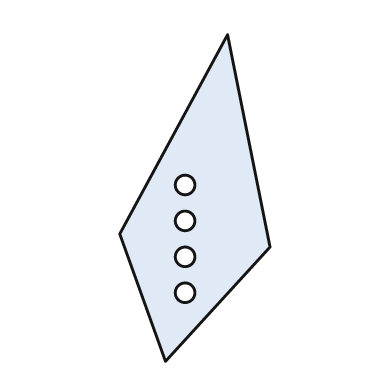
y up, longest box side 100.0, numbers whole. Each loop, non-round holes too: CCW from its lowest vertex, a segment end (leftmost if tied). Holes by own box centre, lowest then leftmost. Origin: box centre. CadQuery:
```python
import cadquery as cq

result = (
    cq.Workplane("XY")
    .moveTo(-9.0, -50.0)
    .lineTo(23.0, -15.0)
    .lineTo(10.0, 50.0)
    .lineTo(-23.0, -11.0)
    .close()
    .moveTo(-3.0, -29.0)
    .circle(3.0)
    .moveTo(-3.0, -18.0)
    .circle(3.0)
    .moveTo(-3.0, -7.0)
    .circle(3.0)
    .moveTo(-3.0, 4.0)
    .circle(3.0)
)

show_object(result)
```